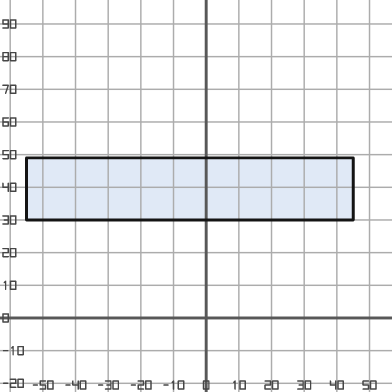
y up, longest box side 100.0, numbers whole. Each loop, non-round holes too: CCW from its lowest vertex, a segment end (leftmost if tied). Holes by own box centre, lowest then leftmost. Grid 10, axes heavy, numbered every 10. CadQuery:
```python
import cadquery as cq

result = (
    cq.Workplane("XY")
    .moveTo(-55.0, 30.0)
    .lineTo(45.0, 30.0)
    .lineTo(45.0, 49.0)
    .lineTo(-55.0, 49.0)
    .close()
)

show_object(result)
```